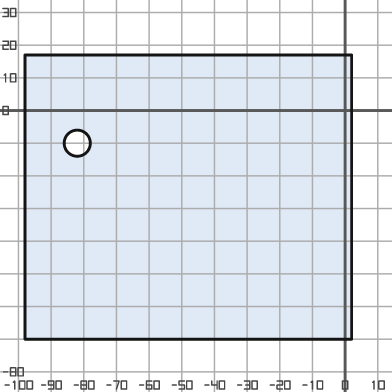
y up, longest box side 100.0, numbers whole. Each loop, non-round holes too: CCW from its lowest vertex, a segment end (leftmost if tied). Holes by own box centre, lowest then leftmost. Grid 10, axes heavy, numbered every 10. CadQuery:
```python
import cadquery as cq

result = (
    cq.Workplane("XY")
    .moveTo(-98.0, -70.0)
    .lineTo(2.0, -70.0)
    .lineTo(2.0, 17.0)
    .lineTo(-98.0, 17.0)
    .close()
    .moveTo(-82.0, -10.0)
    .circle(4.0)
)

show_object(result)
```